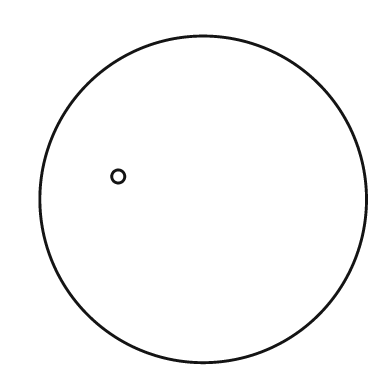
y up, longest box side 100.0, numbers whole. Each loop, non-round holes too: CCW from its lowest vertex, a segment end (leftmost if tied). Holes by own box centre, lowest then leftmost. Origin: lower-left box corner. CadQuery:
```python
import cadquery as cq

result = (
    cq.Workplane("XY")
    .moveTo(50.0, 50.0)
    .circle(50.0)
    .moveTo(24.0, 57.0)
    .circle(2.0)
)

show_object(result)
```